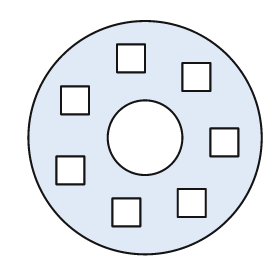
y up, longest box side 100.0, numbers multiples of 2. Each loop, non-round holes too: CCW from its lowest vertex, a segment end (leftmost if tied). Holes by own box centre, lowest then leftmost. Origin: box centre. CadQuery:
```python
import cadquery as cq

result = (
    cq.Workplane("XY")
    .moveTo(0.0, 0.0)
    .circle(50.0)
    .moveTo(-14.0, -38.0)
    .lineTo(-2.0, -38.0)
    .lineTo(-2.0, -26.0)
    .lineTo(-14.0, -26.0)
    .close()
    .moveTo(14.0, -34.0)
    .lineTo(26.0, -34.0)
    .lineTo(26.0, -22.0)
    .lineTo(14.0, -22.0)
    .close()
    .moveTo(-38.0, -20.0)
    .lineTo(-26.0, -20.0)
    .lineTo(-26.0, -8.0)
    .lineTo(-38.0, -8.0)
    .close()
    .moveTo(28.0, -8.0)
    .lineTo(40.0, -8.0)
    .lineTo(40.0, 4.0)
    .lineTo(28.0, 4.0)
    .close()
    .moveTo(0.0, 0.0)
    .circle(16.0)
    .moveTo(-36.0, 10.0)
    .lineTo(-24.0, 10.0)
    .lineTo(-24.0, 22.0)
    .lineTo(-36.0, 22.0)
    .close()
    .moveTo(16.0, 20.0)
    .lineTo(28.0, 20.0)
    .lineTo(28.0, 32.0)
    .lineTo(16.0, 32.0)
    .close()
    .moveTo(-12.0, 28.0)
    .lineTo(0.0, 28.0)
    .lineTo(0.0, 40.0)
    .lineTo(-12.0, 40.0)
    .close()
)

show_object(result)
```